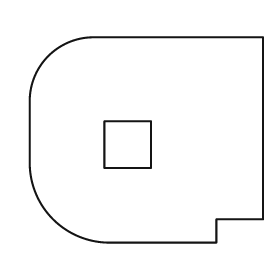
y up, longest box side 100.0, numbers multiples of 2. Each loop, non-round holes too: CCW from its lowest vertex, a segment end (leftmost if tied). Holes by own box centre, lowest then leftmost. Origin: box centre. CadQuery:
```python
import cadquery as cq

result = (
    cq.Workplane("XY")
    .moveTo(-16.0, -44.0)
    .lineTo(30.0, -44.0)
    .lineTo(30.0, -34.0)
    .lineTo(50.0, -34.0)
    .lineTo(50.0, 44.0)
    .lineTo(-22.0, 44.0)
    .threePointArc((-42.0, 36.0), (-50.0, 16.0))
    .lineTo(-50.0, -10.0)
    .threePointArc((-40.0, -34.0), (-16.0, -44.0))
    .close()
    .moveTo(-18.0, -12.0)
    .lineTo(2.0, -12.0)
    .lineTo(2.0, 8.0)
    .lineTo(-18.0, 8.0)
    .close()
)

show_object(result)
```